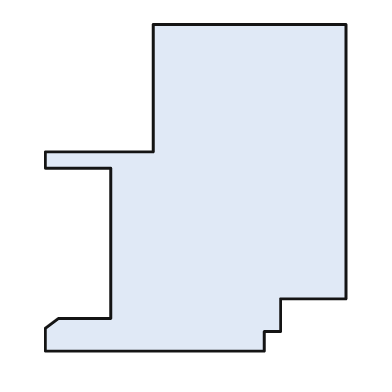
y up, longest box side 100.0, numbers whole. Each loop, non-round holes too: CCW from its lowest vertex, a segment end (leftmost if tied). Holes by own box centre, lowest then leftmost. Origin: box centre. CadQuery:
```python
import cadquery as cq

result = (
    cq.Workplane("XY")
    .moveTo(-46.0, -50.0)
    .lineTo(21.0, -50.0)
    .lineTo(21.0, -44.0)
    .lineTo(26.0, -44.0)
    .lineTo(26.0, -34.0)
    .lineTo(46.0, -34.0)
    .lineTo(46.0, 50.0)
    .lineTo(-13.0, 50.0)
    .lineTo(-13.0, 11.0)
    .lineTo(-46.0, 11.0)
    .lineTo(-46.0, 6.0)
    .lineTo(-26.0, 6.0)
    .lineTo(-26.0, -40.0)
    .lineTo(-42.0, -40.0)
    .lineTo(-46.0, -43.0)
    .close()
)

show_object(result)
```